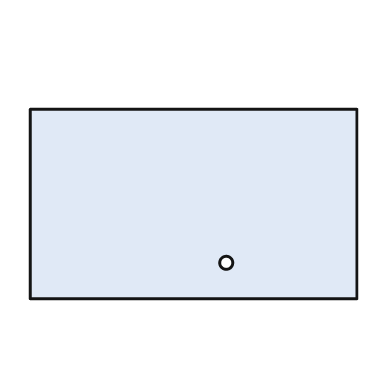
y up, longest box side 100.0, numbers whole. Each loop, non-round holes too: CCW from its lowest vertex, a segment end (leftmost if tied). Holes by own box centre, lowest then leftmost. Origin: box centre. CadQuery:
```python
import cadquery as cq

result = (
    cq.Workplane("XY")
    .moveTo(-50.0, -29.0)
    .lineTo(50.0, -29.0)
    .lineTo(50.0, 29.0)
    .lineTo(-50.0, 29.0)
    .close()
    .moveTo(10.0, -18.0)
    .circle(2.0)
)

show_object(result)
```